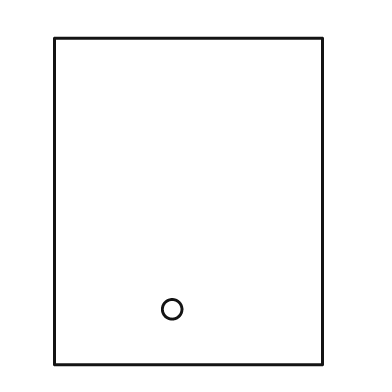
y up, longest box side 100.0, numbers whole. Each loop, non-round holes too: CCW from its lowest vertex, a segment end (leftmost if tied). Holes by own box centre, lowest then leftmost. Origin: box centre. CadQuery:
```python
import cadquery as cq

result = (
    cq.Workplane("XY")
    .moveTo(-41.0, -50.0)
    .lineTo(41.0, -50.0)
    .lineTo(41.0, 50.0)
    .lineTo(-41.0, 50.0)
    .close()
    .moveTo(-5.0, -33.0)
    .circle(3.0)
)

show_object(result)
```